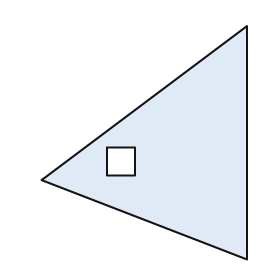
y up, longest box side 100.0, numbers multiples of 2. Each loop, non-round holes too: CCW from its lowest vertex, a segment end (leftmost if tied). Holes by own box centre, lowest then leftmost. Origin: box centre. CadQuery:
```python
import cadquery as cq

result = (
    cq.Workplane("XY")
    .moveTo(44.0, -50.0)
    .lineTo(44.0, 50.0)
    .lineTo(-44.0, -16.0)
    .close()
    .moveTo(-16.0, -14.0)
    .lineTo(-4.0, -14.0)
    .lineTo(-4.0, -2.0)
    .lineTo(-16.0, -2.0)
    .close()
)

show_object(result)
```